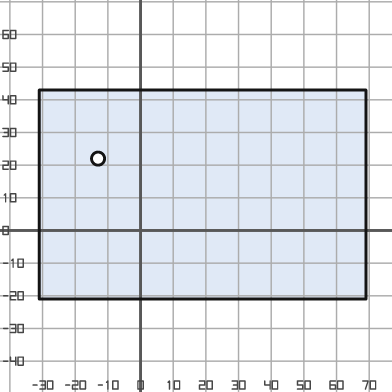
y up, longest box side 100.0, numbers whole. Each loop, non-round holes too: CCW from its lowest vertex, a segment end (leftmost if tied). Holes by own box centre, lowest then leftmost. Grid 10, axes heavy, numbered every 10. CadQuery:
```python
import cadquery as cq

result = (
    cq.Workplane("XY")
    .moveTo(-31.0, -21.0)
    .lineTo(69.0, -21.0)
    .lineTo(69.0, 43.0)
    .lineTo(-31.0, 43.0)
    .close()
    .moveTo(-13.0, 22.0)
    .circle(2.0)
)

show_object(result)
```